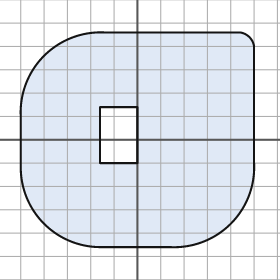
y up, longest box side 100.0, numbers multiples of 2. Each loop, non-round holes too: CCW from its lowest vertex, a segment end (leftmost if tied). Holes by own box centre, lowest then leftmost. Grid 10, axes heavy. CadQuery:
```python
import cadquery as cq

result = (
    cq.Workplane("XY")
    .moveTo(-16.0, -46.0)
    .lineTo(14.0, -46.0)
    .threePointArc((40.0, -36.0), (50.0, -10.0))
    .lineTo(50.0, 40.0)
    .threePointArc((48.0, 44.0), (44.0, 46.0))
    .lineTo(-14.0, 46.0)
    .threePointArc((-40.0, 36.0), (-50.0, 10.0))
    .lineTo(-50.0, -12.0)
    .threePointArc((-40.0, -36.0), (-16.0, -46.0))
    .close()
    .moveTo(-16.0, -10.0)
    .lineTo(0.0, -10.0)
    .lineTo(0.0, 14.0)
    .lineTo(-16.0, 14.0)
    .close()
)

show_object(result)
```